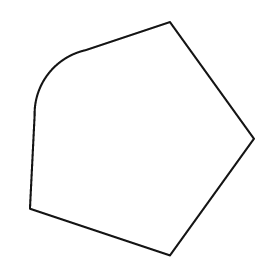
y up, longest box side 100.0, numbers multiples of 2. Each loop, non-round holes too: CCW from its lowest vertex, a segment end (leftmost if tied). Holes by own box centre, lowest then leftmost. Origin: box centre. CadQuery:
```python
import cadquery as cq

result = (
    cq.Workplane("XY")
    .moveTo(12.0, -50.0)
    .lineTo(48.0, 0.0)
    .lineTo(12.0, 50.0)
    .lineTo(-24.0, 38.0)
    .threePointArc((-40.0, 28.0), (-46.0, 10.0))
    .lineTo(-48.0, -30.0)
    .close()
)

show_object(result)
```